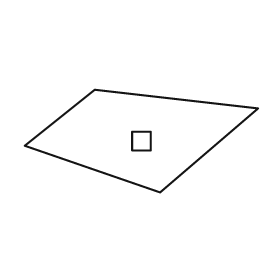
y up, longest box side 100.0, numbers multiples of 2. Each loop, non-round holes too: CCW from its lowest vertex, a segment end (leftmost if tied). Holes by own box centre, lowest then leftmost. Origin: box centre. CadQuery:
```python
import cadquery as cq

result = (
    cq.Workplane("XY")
    .moveTo(8.0, -22.0)
    .lineTo(50.0, 14.0)
    .lineTo(-20.0, 22.0)
    .lineTo(-50.0, -2.0)
    .close()
    .moveTo(-4.0, -4.0)
    .lineTo(4.0, -4.0)
    .lineTo(4.0, 4.0)
    .lineTo(-4.0, 4.0)
    .close()
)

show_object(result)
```